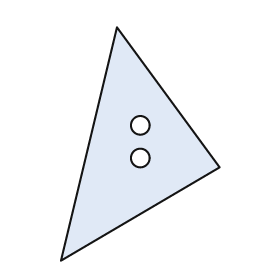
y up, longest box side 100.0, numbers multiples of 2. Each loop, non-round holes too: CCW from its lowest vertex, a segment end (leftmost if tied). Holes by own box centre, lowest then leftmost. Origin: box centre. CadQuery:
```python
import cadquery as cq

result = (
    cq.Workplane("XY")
    .moveTo(-34.0, -50.0)
    .lineTo(34.0, -10.0)
    .lineTo(-10.0, 50.0)
    .close()
    .moveTo(0.0, -6.0)
    .circle(4.0)
    .moveTo(0.0, 8.0)
    .circle(4.0)
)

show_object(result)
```